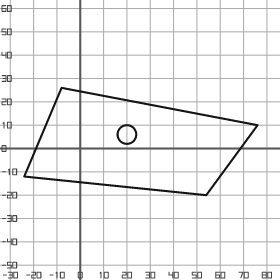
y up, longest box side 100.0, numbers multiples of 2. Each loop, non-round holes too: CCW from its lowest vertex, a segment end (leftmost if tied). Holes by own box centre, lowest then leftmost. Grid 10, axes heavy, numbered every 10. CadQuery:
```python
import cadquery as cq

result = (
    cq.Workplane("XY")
    .moveTo(54.0, -20.0)
    .lineTo(76.0, 10.0)
    .lineTo(-8.0, 26.0)
    .lineTo(-24.0, -12.0)
    .close()
    .moveTo(20.0, 6.0)
    .circle(4.0)
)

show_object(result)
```